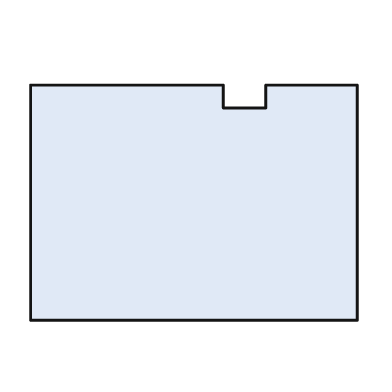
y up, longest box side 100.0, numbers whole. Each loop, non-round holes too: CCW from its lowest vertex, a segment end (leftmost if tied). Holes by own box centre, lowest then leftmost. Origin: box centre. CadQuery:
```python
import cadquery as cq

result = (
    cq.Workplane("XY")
    .moveTo(-50.0, -36.0)
    .lineTo(50.0, -36.0)
    .lineTo(50.0, 36.0)
    .lineTo(22.0, 36.0)
    .lineTo(22.0, 29.0)
    .lineTo(9.0, 29.0)
    .lineTo(9.0, 36.0)
    .lineTo(-50.0, 36.0)
    .close()
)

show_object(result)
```